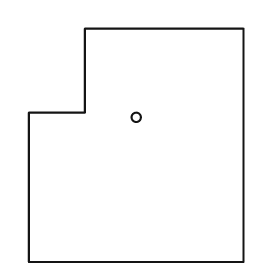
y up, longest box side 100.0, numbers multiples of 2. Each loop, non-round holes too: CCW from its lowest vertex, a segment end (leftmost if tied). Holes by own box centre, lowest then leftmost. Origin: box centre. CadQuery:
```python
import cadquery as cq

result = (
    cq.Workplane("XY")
    .moveTo(-46.0, -50.0)
    .lineTo(46.0, -50.0)
    .lineTo(46.0, 50.0)
    .lineTo(-22.0, 50.0)
    .lineTo(-22.0, 14.0)
    .lineTo(-46.0, 14.0)
    .close()
    .moveTo(0.0, 12.0)
    .circle(2.0)
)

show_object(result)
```